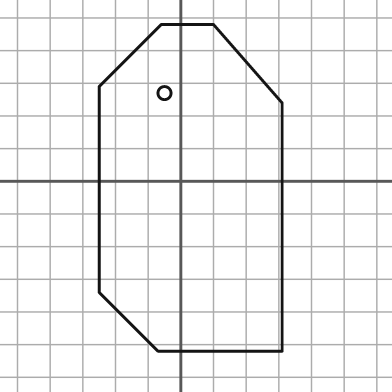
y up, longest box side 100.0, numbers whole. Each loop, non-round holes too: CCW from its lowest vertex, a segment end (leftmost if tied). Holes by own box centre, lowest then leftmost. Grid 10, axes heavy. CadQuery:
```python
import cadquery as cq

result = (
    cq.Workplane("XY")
    .moveTo(-7.0, -52.0)
    .lineTo(31.0, -52.0)
    .lineTo(31.0, 24.0)
    .lineTo(10.0, 48.0)
    .lineTo(-6.0, 48.0)
    .lineTo(-25.0, 29.0)
    .lineTo(-25.0, -34.0)
    .close()
    .moveTo(-5.0, 27.0)
    .circle(2.0)
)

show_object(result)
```